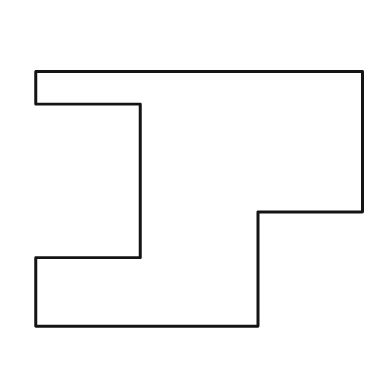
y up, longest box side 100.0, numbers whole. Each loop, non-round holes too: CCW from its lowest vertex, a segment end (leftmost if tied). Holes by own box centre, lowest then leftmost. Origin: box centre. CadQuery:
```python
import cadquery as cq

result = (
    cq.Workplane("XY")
    .moveTo(-50.0, -39.0)
    .lineTo(18.0, -39.0)
    .lineTo(18.0, -4.0)
    .lineTo(50.0, -4.0)
    .lineTo(50.0, 39.0)
    .lineTo(-50.0, 39.0)
    .lineTo(-50.0, 29.0)
    .lineTo(-18.0, 29.0)
    .lineTo(-18.0, -18.0)
    .lineTo(-50.0, -18.0)
    .close()
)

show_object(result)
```